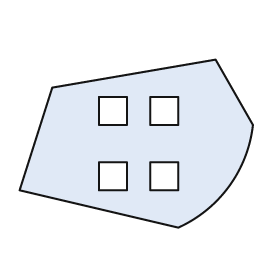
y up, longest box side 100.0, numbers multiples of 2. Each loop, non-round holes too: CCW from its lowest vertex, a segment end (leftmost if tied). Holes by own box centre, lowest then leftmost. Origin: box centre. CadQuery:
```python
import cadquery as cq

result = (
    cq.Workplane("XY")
    .moveTo(18.0, -36.0)
    .threePointArc((40.0, -18.0), (50.0, 8.0))
    .lineTo(34.0, 36.0)
    .lineTo(-36.0, 24.0)
    .lineTo(-50.0, -20.0)
    .close()
    .moveTo(-16.0, -20.0)
    .lineTo(-4.0, -20.0)
    .lineTo(-4.0, -8.0)
    .lineTo(-16.0, -8.0)
    .close()
    .moveTo(6.0, -20.0)
    .lineTo(18.0, -20.0)
    .lineTo(18.0, -8.0)
    .lineTo(6.0, -8.0)
    .close()
    .moveTo(-16.0, 8.0)
    .lineTo(-4.0, 8.0)
    .lineTo(-4.0, 20.0)
    .lineTo(-16.0, 20.0)
    .close()
    .moveTo(6.0, 8.0)
    .lineTo(18.0, 8.0)
    .lineTo(18.0, 20.0)
    .lineTo(6.0, 20.0)
    .close()
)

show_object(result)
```